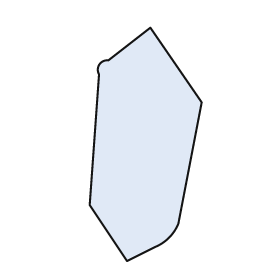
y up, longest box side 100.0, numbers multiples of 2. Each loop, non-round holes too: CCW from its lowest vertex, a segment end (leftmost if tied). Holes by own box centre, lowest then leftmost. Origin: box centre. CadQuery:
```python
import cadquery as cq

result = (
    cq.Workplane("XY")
    .moveTo(-8.0, -50.0)
    .lineTo(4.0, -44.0)
    .threePointArc((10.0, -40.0), (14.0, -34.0))
    .lineTo(24.0, 18.0)
    .lineTo(2.0, 50.0)
    .lineTo(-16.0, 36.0)
    .threePointArc((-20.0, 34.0), (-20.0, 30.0))
    .lineTo(-24.0, -26.0)
    .close()
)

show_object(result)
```